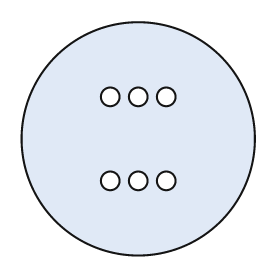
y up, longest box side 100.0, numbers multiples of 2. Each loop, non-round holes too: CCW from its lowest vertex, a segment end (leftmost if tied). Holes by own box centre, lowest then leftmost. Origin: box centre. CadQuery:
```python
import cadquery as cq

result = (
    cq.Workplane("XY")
    .moveTo(0.0, 0.0)
    .circle(50.0)
    .moveTo(-12.0, -18.0)
    .circle(4.0)
    .moveTo(0.0, -18.0)
    .circle(4.0)
    .moveTo(12.0, -18.0)
    .circle(4.0)
    .moveTo(-12.0, 18.0)
    .circle(4.0)
    .moveTo(0.0, 18.0)
    .circle(4.0)
    .moveTo(12.0, 18.0)
    .circle(4.0)
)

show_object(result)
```